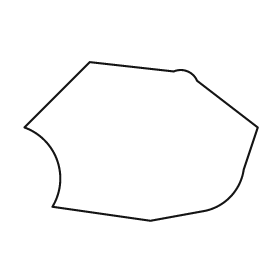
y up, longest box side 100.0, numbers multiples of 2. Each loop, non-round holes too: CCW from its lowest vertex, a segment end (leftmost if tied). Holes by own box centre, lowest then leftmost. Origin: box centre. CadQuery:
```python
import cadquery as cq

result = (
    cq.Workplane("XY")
    .moveTo(4.0, -34.0)
    .lineTo(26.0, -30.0)
    .threePointArc((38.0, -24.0), (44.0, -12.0))
    .lineTo(50.0, 6.0)
    .lineTo(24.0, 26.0)
    .threePointArc((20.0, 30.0), (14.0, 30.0))
    .lineTo(-22.0, 34.0)
    .lineTo(-50.0, 6.0)
    .threePointArc((-36.0, -8.0), (-38.0, -28.0))
    .close()
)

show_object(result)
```